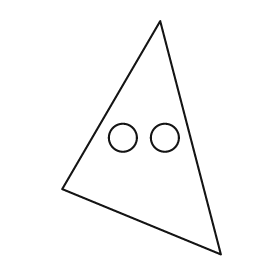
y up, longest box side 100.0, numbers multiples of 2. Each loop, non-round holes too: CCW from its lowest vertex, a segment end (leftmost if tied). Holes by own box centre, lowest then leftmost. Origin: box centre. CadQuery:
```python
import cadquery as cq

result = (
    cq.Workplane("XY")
    .moveTo(34.0, -50.0)
    .lineTo(8.0, 50.0)
    .lineTo(-34.0, -22.0)
    .close()
    .moveTo(-8.0, 0.0)
    .circle(6.0)
    .moveTo(10.0, 0.0)
    .circle(6.0)
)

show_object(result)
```